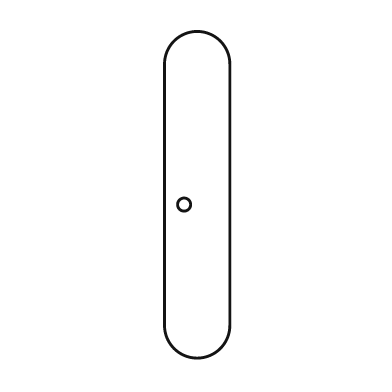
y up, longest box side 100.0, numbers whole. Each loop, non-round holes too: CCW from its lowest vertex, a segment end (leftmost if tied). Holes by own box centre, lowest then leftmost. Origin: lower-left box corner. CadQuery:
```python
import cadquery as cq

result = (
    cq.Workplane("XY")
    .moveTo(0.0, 10.0)
    .threePointArc((10.0, 0.0), (20.0, 10.0))
    .lineTo(20.0, 90.0)
    .threePointArc((10.0, 100.0), (0.0, 90.0))
    .close()
    .moveTo(6.0, 47.0)
    .circle(2.0)
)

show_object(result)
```